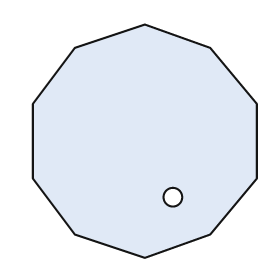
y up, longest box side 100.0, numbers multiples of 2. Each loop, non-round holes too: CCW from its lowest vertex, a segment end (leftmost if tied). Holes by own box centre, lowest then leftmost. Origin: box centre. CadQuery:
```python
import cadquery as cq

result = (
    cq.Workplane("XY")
    .moveTo(0.0, -50.0)
    .lineTo(28.0, -40.0)
    .lineTo(48.0, -16.0)
    .lineTo(48.0, 16.0)
    .lineTo(28.0, 40.0)
    .lineTo(0.0, 50.0)
    .lineTo(-30.0, 40.0)
    .lineTo(-48.0, 16.0)
    .lineTo(-48.0, -16.0)
    .lineTo(-30.0, -40.0)
    .close()
    .moveTo(12.0, -24.0)
    .circle(4.0)
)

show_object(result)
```